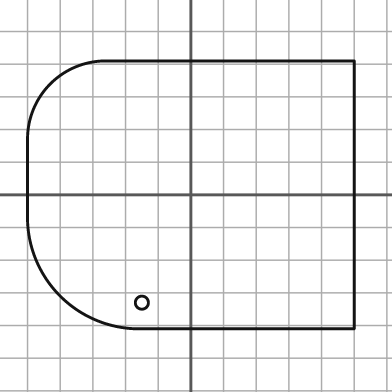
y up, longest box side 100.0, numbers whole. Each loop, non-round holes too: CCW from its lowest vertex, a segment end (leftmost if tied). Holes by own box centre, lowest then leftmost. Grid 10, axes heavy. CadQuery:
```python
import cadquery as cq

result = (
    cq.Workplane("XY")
    .moveTo(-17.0, -41.0)
    .lineTo(50.0, -41.0)
    .lineTo(50.0, 41.0)
    .lineTo(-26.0, 41.0)
    .threePointArc((-43.0, 34.0), (-50.0, 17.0))
    .lineTo(-50.0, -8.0)
    .threePointArc((-40.0, -31.0), (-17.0, -41.0))
    .close()
    .moveTo(-15.0, -33.0)
    .circle(2.0)
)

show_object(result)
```